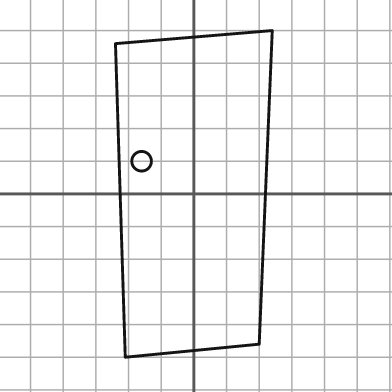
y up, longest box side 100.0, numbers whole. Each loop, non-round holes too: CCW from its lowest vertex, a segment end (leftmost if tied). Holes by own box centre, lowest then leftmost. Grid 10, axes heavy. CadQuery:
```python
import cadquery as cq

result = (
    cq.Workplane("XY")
    .moveTo(-21.0, -50.0)
    .lineTo(20.0, -46.0)
    .lineTo(24.0, 50.0)
    .lineTo(-24.0, 46.0)
    .close()
    .moveTo(-16.0, 10.0)
    .circle(3.0)
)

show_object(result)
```